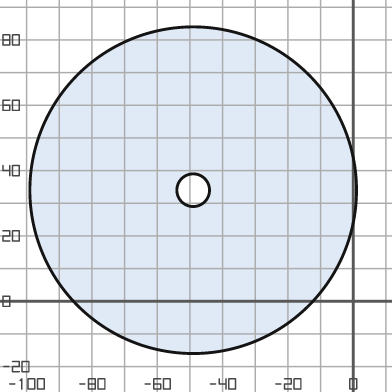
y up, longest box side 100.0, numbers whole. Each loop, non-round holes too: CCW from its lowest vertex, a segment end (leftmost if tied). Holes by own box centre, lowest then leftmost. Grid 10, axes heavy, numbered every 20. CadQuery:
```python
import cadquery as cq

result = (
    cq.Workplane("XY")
    .moveTo(-49.0, 34.0)
    .circle(50.0)
    .moveTo(-49.0, 34.0)
    .circle(5.0)
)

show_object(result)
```